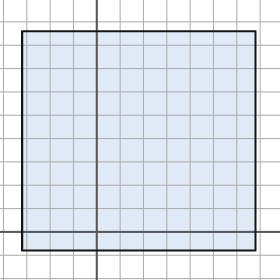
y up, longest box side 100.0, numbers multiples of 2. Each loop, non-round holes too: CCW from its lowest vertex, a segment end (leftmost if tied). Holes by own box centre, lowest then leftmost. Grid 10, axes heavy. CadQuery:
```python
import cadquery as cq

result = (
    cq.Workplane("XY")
    .moveTo(-32.0, -8.0)
    .lineTo(68.0, -8.0)
    .lineTo(68.0, 86.0)
    .lineTo(-32.0, 86.0)
    .close()
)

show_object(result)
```